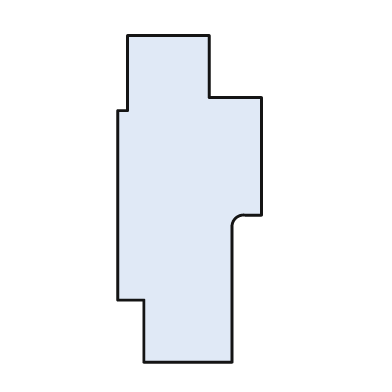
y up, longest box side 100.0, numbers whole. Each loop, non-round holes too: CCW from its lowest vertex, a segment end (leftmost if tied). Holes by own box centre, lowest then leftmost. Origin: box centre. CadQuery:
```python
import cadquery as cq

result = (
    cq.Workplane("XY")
    .moveTo(-14.0, -50.0)
    .lineTo(13.0, -50.0)
    .lineTo(13.0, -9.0)
    .threePointArc((14.0, -6.0), (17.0, -5.0))
    .lineTo(22.0, -5.0)
    .lineTo(22.0, 31.0)
    .lineTo(6.0, 31.0)
    .lineTo(6.0, 50.0)
    .lineTo(-19.0, 50.0)
    .lineTo(-19.0, 27.0)
    .lineTo(-22.0, 27.0)
    .lineTo(-22.0, -31.0)
    .lineTo(-14.0, -31.0)
    .close()
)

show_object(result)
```